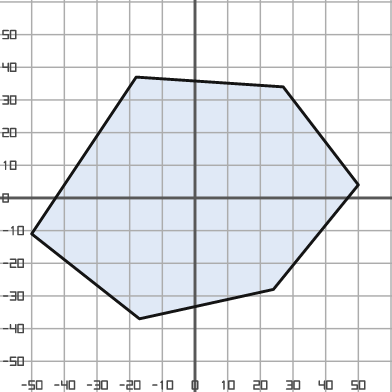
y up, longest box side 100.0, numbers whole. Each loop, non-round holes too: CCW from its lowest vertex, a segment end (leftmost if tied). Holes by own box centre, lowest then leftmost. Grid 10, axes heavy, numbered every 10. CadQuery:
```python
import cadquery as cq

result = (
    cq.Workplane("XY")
    .moveTo(-17.0, -37.0)
    .lineTo(24.0, -28.0)
    .lineTo(50.0, 4.0)
    .lineTo(27.0, 34.0)
    .lineTo(-18.0, 37.0)
    .lineTo(-50.0, -11.0)
    .close()
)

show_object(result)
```